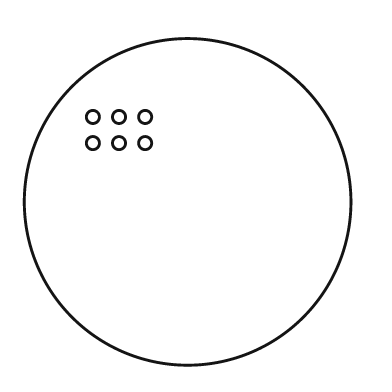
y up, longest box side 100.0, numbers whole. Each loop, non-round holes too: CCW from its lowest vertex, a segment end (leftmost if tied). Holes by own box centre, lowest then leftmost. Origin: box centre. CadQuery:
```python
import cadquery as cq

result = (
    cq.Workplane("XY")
    .moveTo(0.0, 0.0)
    .circle(50.0)
    .moveTo(-29.0, 18.0)
    .circle(2.0)
    .moveTo(-21.0, 18.0)
    .circle(2.0)
    .moveTo(-13.0, 18.0)
    .circle(2.0)
    .moveTo(-29.0, 26.0)
    .circle(2.0)
    .moveTo(-21.0, 26.0)
    .circle(2.0)
    .moveTo(-13.0, 26.0)
    .circle(2.0)
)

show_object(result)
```